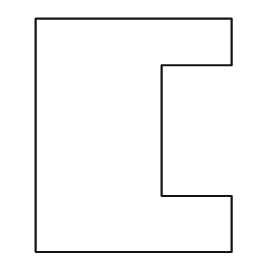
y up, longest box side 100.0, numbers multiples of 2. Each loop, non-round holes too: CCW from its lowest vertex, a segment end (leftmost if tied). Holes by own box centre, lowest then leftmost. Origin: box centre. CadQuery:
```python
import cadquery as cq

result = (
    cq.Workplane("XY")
    .moveTo(-42.0, -50.0)
    .lineTo(42.0, -50.0)
    .lineTo(42.0, -26.0)
    .lineTo(12.0, -26.0)
    .lineTo(12.0, 30.0)
    .lineTo(42.0, 30.0)
    .lineTo(42.0, 50.0)
    .lineTo(-42.0, 50.0)
    .close()
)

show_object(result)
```